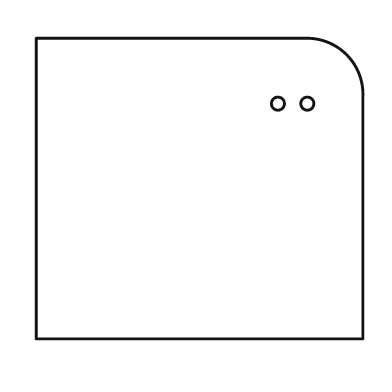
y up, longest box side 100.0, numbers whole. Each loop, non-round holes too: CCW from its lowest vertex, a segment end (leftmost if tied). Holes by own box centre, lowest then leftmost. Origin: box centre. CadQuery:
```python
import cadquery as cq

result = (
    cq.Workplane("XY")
    .moveTo(-50.0, -46.0)
    .lineTo(50.0, -46.0)
    .lineTo(50.0, 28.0)
    .threePointArc((45.0, 41.0), (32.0, 46.0))
    .lineTo(-50.0, 46.0)
    .close()
    .moveTo(24.0, 26.0)
    .circle(2.0)
    .moveTo(33.0, 26.0)
    .circle(2.0)
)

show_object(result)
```